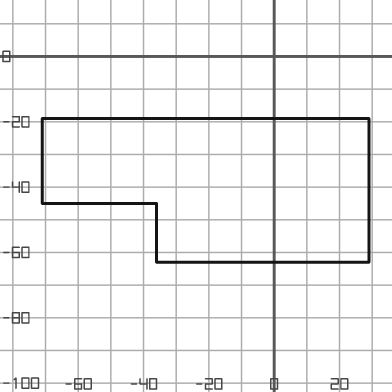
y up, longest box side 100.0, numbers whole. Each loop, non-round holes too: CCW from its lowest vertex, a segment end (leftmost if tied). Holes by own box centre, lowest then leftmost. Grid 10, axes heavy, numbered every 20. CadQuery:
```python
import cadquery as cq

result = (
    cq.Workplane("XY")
    .moveTo(-36.0, -63.0)
    .lineTo(29.0, -63.0)
    .lineTo(29.0, -19.0)
    .lineTo(-71.0, -19.0)
    .lineTo(-71.0, -45.0)
    .lineTo(-36.0, -45.0)
    .close()
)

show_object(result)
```